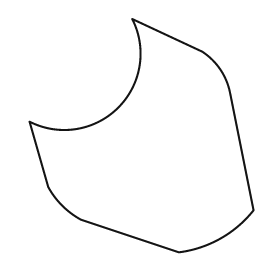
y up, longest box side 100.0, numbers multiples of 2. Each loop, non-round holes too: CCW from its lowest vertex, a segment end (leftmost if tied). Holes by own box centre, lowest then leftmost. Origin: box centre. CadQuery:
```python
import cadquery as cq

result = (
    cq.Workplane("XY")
    .moveTo(16.0, -50.0)
    .threePointArc((34.0, -44.0), (48.0, -32.0))
    .lineTo(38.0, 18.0)
    .threePointArc((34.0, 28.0), (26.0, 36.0))
    .lineTo(-4.0, 50.0)
    .threePointArc((-10.0, 12.0), (-48.0, 6.0))
    .lineTo(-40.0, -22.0)
    .threePointArc((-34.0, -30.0), (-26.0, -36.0))
    .close()
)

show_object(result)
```